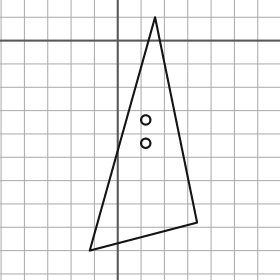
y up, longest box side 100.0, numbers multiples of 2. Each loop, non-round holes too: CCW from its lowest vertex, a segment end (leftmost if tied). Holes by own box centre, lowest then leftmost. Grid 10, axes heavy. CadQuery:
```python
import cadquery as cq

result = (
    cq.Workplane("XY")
    .moveTo(-12.0, -90.0)
    .lineTo(34.0, -78.0)
    .lineTo(16.0, 10.0)
    .close()
    .moveTo(12.0, -44.0)
    .circle(2.0)
    .moveTo(12.0, -34.0)
    .circle(2.0)
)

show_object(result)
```